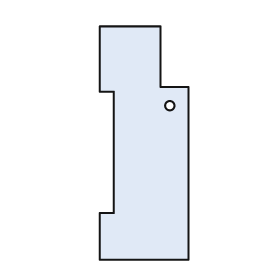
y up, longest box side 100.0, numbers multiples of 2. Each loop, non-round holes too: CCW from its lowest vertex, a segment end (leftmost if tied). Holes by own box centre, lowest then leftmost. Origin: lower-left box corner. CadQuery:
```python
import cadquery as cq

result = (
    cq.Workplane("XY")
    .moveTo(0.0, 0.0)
    .lineTo(38.0, 0.0)
    .lineTo(38.0, 74.0)
    .lineTo(26.0, 74.0)
    .lineTo(26.0, 100.0)
    .lineTo(0.0, 100.0)
    .lineTo(0.0, 72.0)
    .lineTo(6.0, 72.0)
    .lineTo(6.0, 20.0)
    .lineTo(0.0, 20.0)
    .close()
    .moveTo(30.0, 66.0)
    .circle(2.0)
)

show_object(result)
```